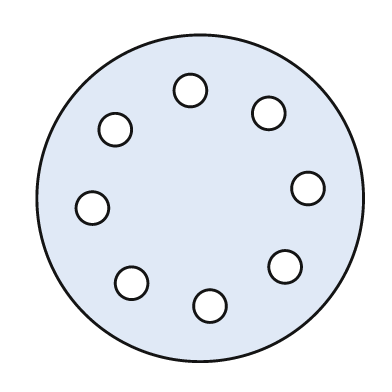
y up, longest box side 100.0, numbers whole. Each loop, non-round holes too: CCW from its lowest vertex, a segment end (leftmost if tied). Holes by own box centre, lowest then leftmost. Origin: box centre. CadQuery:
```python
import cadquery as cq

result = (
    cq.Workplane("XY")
    .moveTo(0.0, 0.0)
    .circle(50.0)
    .moveTo(3.0, -33.0)
    .circle(5.0)
    .moveTo(-21.0, -26.0)
    .circle(5.0)
    .moveTo(26.0, -21.0)
    .circle(5.0)
    .moveTo(-33.0, -3.0)
    .circle(5.0)
    .moveTo(33.0, 3.0)
    .circle(5.0)
    .moveTo(-26.0, 21.0)
    .circle(5.0)
    .moveTo(21.0, 26.0)
    .circle(5.0)
    .moveTo(-3.0, 33.0)
    .circle(5.0)
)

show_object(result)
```